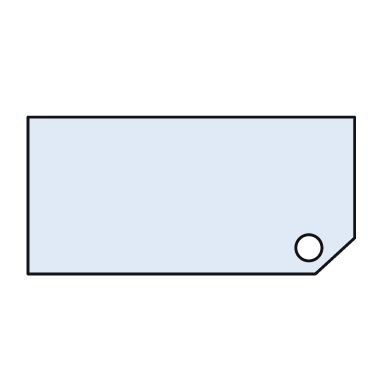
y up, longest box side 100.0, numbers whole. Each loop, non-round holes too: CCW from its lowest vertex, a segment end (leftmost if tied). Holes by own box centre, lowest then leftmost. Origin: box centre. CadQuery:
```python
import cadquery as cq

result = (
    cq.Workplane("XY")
    .moveTo(-50.0, -24.0)
    .lineTo(38.0, -24.0)
    .lineTo(50.0, -13.0)
    .lineTo(50.0, 24.0)
    .lineTo(-50.0, 24.0)
    .close()
    .moveTo(36.0, -16.0)
    .circle(4.0)
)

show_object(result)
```